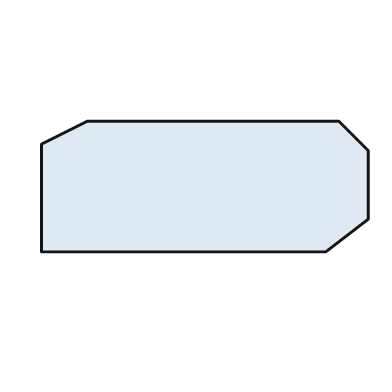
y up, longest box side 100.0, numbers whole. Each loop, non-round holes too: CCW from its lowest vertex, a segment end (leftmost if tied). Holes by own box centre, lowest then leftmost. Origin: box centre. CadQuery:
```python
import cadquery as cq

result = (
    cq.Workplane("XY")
    .moveTo(-50.0, -20.0)
    .lineTo(37.0, -20.0)
    .lineTo(50.0, -10.0)
    .lineTo(50.0, 11.0)
    .lineTo(41.0, 20.0)
    .lineTo(-36.0, 20.0)
    .lineTo(-50.0, 13.0)
    .close()
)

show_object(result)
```